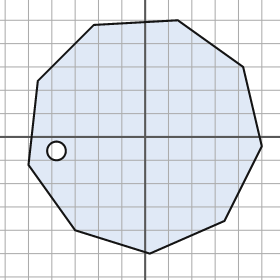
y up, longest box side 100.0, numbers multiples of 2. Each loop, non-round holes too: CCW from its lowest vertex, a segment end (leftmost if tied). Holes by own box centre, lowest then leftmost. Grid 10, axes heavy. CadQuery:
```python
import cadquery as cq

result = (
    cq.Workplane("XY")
    .moveTo(2.0, -50.0)
    .lineTo(34.0, -36.0)
    .lineTo(50.0, -4.0)
    .lineTo(42.0, 30.0)
    .lineTo(14.0, 50.0)
    .lineTo(-22.0, 48.0)
    .lineTo(-46.0, 24.0)
    .lineTo(-50.0, -12.0)
    .lineTo(-30.0, -40.0)
    .close()
    .moveTo(-38.0, -6.0)
    .circle(4.0)
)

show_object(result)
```